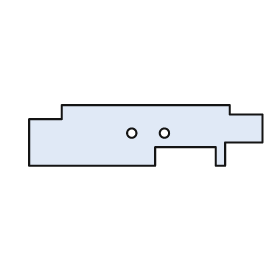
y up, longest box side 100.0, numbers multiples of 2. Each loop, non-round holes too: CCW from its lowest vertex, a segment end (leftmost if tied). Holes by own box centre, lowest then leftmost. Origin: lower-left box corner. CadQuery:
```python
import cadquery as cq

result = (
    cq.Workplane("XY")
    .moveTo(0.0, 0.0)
    .lineTo(54.0, 0.0)
    .lineTo(54.0, 8.0)
    .lineTo(80.0, 8.0)
    .lineTo(80.0, 0.0)
    .lineTo(84.0, 0.0)
    .lineTo(84.0, 10.0)
    .lineTo(100.0, 10.0)
    .lineTo(100.0, 22.0)
    .lineTo(86.0, 22.0)
    .lineTo(86.0, 26.0)
    .lineTo(14.0, 26.0)
    .lineTo(14.0, 20.0)
    .lineTo(0.0, 20.0)
    .close()
    .moveTo(44.0, 14.0)
    .circle(2.0)
    .moveTo(58.0, 14.0)
    .circle(2.0)
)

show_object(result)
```